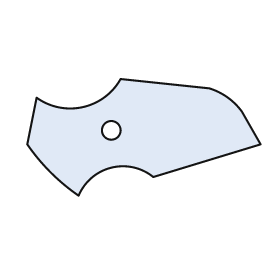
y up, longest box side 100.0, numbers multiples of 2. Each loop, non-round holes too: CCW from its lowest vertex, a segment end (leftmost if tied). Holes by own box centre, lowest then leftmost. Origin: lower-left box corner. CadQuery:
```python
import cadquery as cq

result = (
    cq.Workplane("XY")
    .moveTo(22.0, 0.0)
    .threePointArc((36.0, 12.0), (54.0, 8.0))
    .lineTo(100.0, 22.0)
    .lineTo(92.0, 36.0)
    .threePointArc((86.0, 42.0), (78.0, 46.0))
    .lineTo(40.0, 50.0)
    .threePointArc((24.0, 38.0), (4.0, 42.0))
    .lineTo(0.0, 22.0)
    .threePointArc((10.0, 10.0), (22.0, 0.0))
    .close()
    .moveTo(36.0, 28.0)
    .circle(4.0)
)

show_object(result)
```